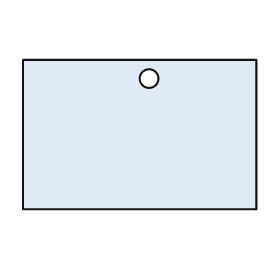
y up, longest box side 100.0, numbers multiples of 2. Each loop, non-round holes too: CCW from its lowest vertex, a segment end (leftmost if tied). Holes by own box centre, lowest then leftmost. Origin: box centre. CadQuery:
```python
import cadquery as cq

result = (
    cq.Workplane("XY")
    .moveTo(-50.0, -32.0)
    .lineTo(50.0, -32.0)
    .lineTo(50.0, 32.0)
    .lineTo(-50.0, 32.0)
    .close()
    .moveTo(4.0, 24.0)
    .circle(4.0)
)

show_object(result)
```